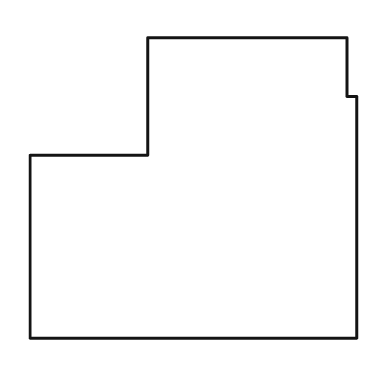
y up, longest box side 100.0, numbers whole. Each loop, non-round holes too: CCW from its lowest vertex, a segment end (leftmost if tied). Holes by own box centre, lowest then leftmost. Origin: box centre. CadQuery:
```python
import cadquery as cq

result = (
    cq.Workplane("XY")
    .moveTo(-50.0, -46.0)
    .lineTo(50.0, -46.0)
    .lineTo(50.0, 28.0)
    .lineTo(47.0, 28.0)
    .lineTo(47.0, 46.0)
    .lineTo(-14.0, 46.0)
    .lineTo(-14.0, 10.0)
    .lineTo(-50.0, 10.0)
    .close()
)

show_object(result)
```